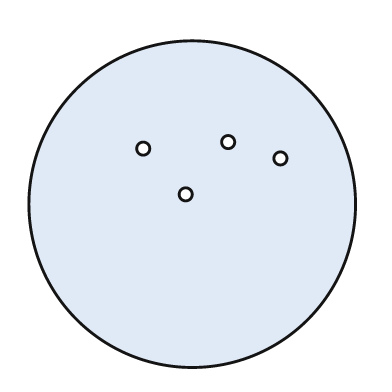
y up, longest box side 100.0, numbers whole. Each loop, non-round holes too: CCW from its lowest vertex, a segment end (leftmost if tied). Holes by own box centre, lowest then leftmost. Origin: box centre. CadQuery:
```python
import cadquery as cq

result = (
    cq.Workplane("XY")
    .moveTo(0.0, 0.0)
    .circle(50.0)
    .moveTo(-2.0, 3.0)
    .circle(2.0)
    .moveTo(27.0, 14.0)
    .circle(2.0)
    .moveTo(-15.0, 17.0)
    .circle(2.0)
    .moveTo(11.0, 19.0)
    .circle(2.0)
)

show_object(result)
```